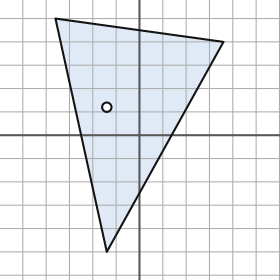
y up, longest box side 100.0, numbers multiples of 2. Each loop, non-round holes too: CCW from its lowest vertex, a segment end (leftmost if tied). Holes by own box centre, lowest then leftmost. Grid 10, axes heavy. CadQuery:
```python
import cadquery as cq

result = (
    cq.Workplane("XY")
    .moveTo(-14.0, -50.0)
    .lineTo(36.0, 40.0)
    .lineTo(-36.0, 50.0)
    .close()
    .moveTo(-14.0, 12.0)
    .circle(2.0)
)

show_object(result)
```